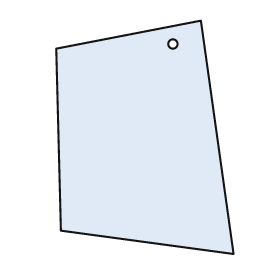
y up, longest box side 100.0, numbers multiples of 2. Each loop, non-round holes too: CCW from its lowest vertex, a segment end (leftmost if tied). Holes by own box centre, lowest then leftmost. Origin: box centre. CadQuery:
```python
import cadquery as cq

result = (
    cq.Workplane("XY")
    .moveTo(38.0, -50.0)
    .lineTo(24.0, 50.0)
    .lineTo(-38.0, 38.0)
    .lineTo(-36.0, -40.0)
    .close()
    .moveTo(12.0, 40.0)
    .circle(2.0)
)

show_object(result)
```